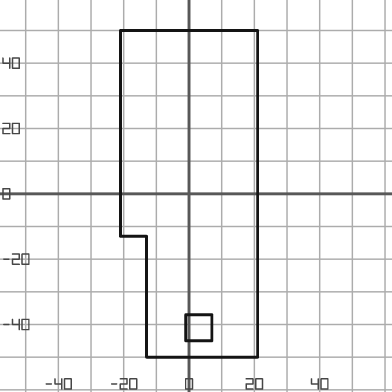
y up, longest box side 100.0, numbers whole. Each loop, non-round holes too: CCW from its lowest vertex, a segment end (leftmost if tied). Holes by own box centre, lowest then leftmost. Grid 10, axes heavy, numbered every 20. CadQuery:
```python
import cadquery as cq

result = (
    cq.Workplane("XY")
    .moveTo(-13.0, -50.0)
    .lineTo(21.0, -50.0)
    .lineTo(21.0, 50.0)
    .lineTo(-21.0, 50.0)
    .lineTo(-21.0, -13.0)
    .lineTo(-13.0, -13.0)
    .close()
    .moveTo(-1.0, -45.0)
    .lineTo(7.0, -45.0)
    .lineTo(7.0, -37.0)
    .lineTo(-1.0, -37.0)
    .close()
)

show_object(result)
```